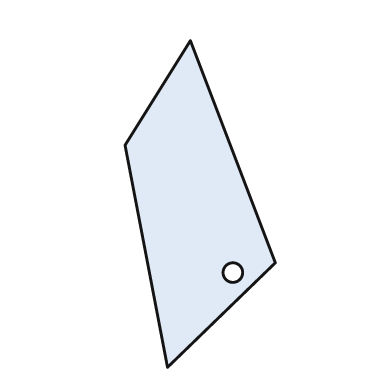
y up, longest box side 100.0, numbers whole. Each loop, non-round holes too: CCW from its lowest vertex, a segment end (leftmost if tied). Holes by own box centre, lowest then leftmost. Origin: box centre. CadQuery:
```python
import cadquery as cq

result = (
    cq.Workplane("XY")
    .moveTo(-10.0, -50.0)
    .lineTo(23.0, -18.0)
    .lineTo(-3.0, 50.0)
    .lineTo(-23.0, 18.0)
    .close()
    .moveTo(10.0, -21.0)
    .circle(3.0)
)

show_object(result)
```